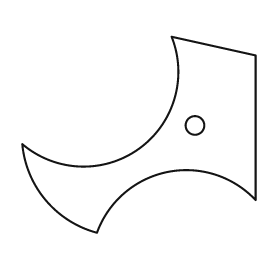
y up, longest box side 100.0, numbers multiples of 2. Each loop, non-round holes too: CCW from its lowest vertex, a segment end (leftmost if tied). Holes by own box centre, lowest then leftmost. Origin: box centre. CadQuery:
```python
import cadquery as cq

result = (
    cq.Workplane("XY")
    .moveTo(-18.0, -42.0)
    .threePointArc((12.0, -16.0), (50.0, -28.0))
    .lineTo(50.0, 34.0)
    .lineTo(14.0, 42.0)
    .threePointArc((0.0, -6.0), (-50.0, -4.0))
    .threePointArc((-40.0, -28.0), (-18.0, -42.0))
    .close()
    .moveTo(24.0, 4.0)
    .circle(4.0)
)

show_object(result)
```